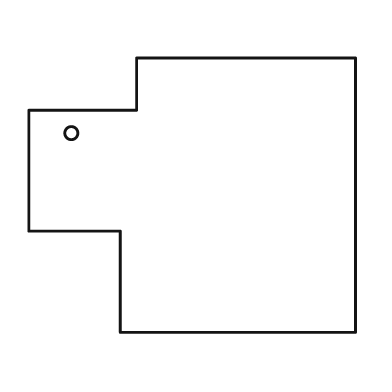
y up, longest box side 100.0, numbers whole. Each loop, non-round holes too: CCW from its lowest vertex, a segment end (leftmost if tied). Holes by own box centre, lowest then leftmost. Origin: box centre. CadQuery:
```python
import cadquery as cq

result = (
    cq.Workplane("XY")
    .moveTo(-22.0, -42.0)
    .lineTo(50.0, -42.0)
    .lineTo(50.0, 42.0)
    .lineTo(-17.0, 42.0)
    .lineTo(-17.0, 26.0)
    .lineTo(-50.0, 26.0)
    .lineTo(-50.0, -11.0)
    .lineTo(-22.0, -11.0)
    .close()
    .moveTo(-37.0, 19.0)
    .circle(2.0)
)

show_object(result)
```